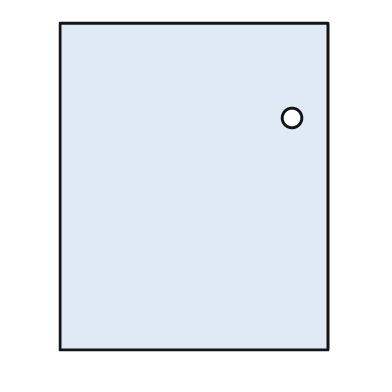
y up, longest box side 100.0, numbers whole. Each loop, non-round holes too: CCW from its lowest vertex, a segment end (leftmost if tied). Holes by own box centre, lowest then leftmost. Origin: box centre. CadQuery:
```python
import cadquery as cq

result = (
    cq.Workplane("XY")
    .moveTo(-41.0, -50.0)
    .lineTo(41.0, -50.0)
    .lineTo(41.0, 50.0)
    .lineTo(-41.0, 50.0)
    .close()
    .moveTo(30.0, 21.0)
    .circle(3.0)
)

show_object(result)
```